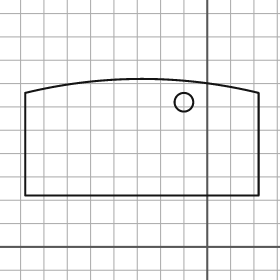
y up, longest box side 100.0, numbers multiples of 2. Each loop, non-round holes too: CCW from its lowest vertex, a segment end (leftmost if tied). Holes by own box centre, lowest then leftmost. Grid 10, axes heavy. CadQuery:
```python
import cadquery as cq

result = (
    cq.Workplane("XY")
    .moveTo(-78.0, 22.0)
    .lineTo(22.0, 22.0)
    .lineTo(22.0, 66.0)
    .threePointArc((-28.0, 72.0), (-78.0, 66.0))
    .close()
    .moveTo(-10.0, 62.0)
    .circle(4.0)
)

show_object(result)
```